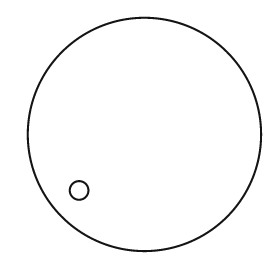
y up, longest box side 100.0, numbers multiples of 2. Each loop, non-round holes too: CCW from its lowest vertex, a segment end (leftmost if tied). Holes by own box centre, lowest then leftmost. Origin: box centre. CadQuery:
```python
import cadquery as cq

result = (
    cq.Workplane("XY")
    .moveTo(0.0, 0.0)
    .circle(50.0)
    .moveTo(-28.0, -24.0)
    .circle(4.0)
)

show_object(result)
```